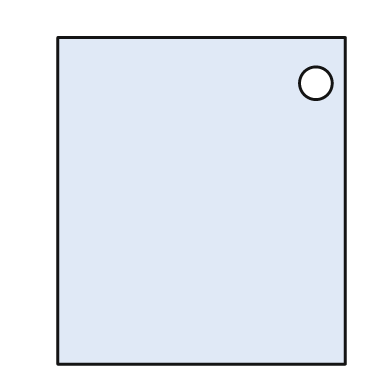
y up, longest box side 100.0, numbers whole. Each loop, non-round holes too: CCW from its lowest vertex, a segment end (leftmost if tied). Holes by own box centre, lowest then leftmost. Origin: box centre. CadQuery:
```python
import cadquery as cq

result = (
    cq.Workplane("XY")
    .moveTo(-44.0, -50.0)
    .lineTo(44.0, -50.0)
    .lineTo(44.0, 50.0)
    .lineTo(-44.0, 50.0)
    .close()
    .moveTo(35.0, 36.0)
    .circle(5.0)
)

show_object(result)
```